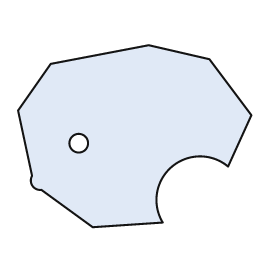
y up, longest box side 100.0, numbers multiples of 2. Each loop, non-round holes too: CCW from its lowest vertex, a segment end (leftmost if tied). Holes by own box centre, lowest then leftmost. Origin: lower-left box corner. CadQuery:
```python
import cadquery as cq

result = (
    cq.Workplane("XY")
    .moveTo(32.0, 0.0)
    .lineTo(62.0, 2.0)
    .threePointArc((66.0, 26.0), (90.0, 26.0))
    .lineTo(100.0, 48.0)
    .lineTo(82.0, 72.0)
    .lineTo(56.0, 78.0)
    .lineTo(14.0, 70.0)
    .lineTo(0.0, 50.0)
    .lineTo(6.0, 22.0)
    .threePointArc((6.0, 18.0), (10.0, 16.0))
    .close()
    .moveTo(26.0, 36.0)
    .circle(4.0)
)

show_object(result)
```